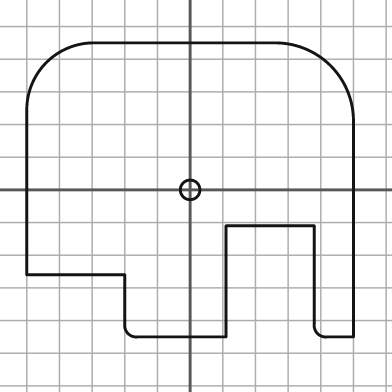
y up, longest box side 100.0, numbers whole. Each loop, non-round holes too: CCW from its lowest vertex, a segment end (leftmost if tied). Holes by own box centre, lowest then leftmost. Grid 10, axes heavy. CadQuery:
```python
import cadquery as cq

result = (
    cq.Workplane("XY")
    .moveTo(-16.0, -45.0)
    .lineTo(11.0, -45.0)
    .lineTo(11.0, -11.0)
    .lineTo(38.0, -11.0)
    .lineTo(38.0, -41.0)
    .threePointArc((39.0, -44.0), (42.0, -45.0))
    .lineTo(50.0, -45.0)
    .lineTo(50.0, 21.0)
    .threePointArc((43.0, 38.0), (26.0, 45.0))
    .lineTo(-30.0, 45.0)
    .threePointArc((-44.0, 39.0), (-50.0, 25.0))
    .lineTo(-50.0, -26.0)
    .lineTo(-20.0, -26.0)
    .lineTo(-20.0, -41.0)
    .threePointArc((-19.0, -44.0), (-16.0, -45.0))
    .close()
    .moveTo(0.0, 0.0)
    .circle(3.0)
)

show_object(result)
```